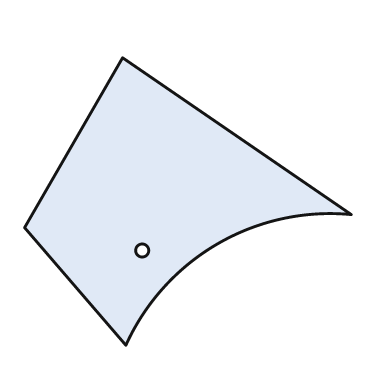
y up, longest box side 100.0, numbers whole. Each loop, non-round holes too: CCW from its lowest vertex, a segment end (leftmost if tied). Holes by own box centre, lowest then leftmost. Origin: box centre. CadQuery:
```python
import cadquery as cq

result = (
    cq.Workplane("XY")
    .moveTo(-19.0, -44.0)
    .threePointArc((9.0, -13.0), (50.0, -4.0))
    .lineTo(-20.0, 44.0)
    .lineTo(-50.0, -8.0)
    .close()
    .moveTo(-14.0, -15.0)
    .circle(2.0)
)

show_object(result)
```